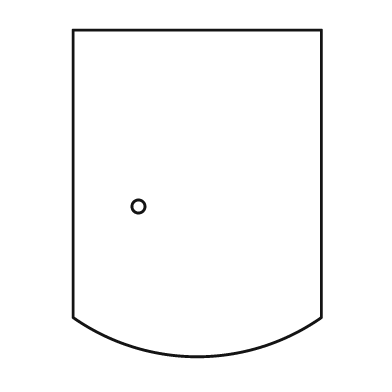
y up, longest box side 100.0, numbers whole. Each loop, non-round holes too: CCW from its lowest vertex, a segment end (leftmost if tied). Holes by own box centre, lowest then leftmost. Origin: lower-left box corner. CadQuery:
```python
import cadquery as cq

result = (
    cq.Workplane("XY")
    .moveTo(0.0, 12.0)
    .threePointArc((38.0, 0.0), (76.0, 12.0))
    .lineTo(76.0, 100.0)
    .lineTo(0.0, 100.0)
    .close()
    .moveTo(20.0, 46.0)
    .circle(2.0)
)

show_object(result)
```